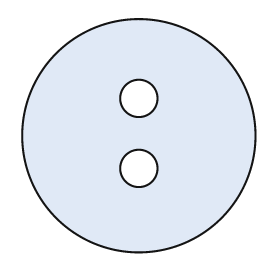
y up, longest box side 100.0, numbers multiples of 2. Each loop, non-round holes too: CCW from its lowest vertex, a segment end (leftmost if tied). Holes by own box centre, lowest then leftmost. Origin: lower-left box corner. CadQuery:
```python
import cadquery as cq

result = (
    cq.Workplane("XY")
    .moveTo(50.0, 50.0)
    .circle(50.0)
    .moveTo(50.0, 36.0)
    .circle(8.0)
    .moveTo(50.0, 66.0)
    .circle(8.0)
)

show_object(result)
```